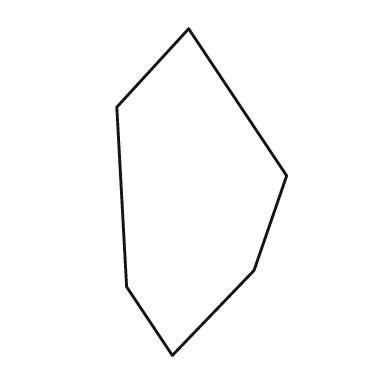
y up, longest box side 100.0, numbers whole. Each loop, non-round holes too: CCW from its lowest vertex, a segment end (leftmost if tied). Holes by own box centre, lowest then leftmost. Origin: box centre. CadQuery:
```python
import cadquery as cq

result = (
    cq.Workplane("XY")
    .moveTo(-9.0, -50.0)
    .lineTo(16.0, -24.0)
    .lineTo(26.0, 5.0)
    .lineTo(-4.0, 50.0)
    .lineTo(-26.0, 26.0)
    .lineTo(-23.0, -29.0)
    .close()
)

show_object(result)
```